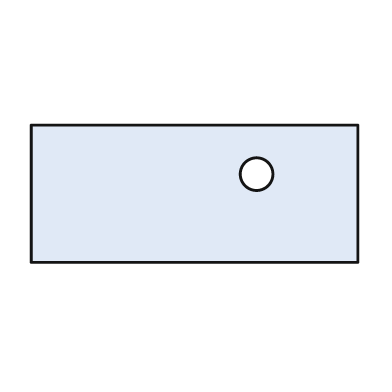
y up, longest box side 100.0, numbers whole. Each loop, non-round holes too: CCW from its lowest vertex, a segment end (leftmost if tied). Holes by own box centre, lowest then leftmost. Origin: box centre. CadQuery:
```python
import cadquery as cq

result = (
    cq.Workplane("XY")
    .moveTo(-50.0, -21.0)
    .lineTo(50.0, -21.0)
    .lineTo(50.0, 21.0)
    .lineTo(-50.0, 21.0)
    .close()
    .moveTo(19.0, 6.0)
    .circle(5.0)
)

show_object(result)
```